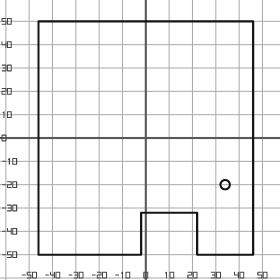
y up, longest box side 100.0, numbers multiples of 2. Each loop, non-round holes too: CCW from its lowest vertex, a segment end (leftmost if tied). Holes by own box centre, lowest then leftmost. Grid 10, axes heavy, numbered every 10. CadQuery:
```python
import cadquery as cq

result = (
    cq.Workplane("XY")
    .moveTo(-46.0, -50.0)
    .lineTo(-2.0, -50.0)
    .lineTo(-2.0, -32.0)
    .lineTo(22.0, -32.0)
    .lineTo(22.0, -50.0)
    .lineTo(46.0, -50.0)
    .lineTo(46.0, 50.0)
    .lineTo(-46.0, 50.0)
    .close()
    .moveTo(34.0, -20.0)
    .circle(2.0)
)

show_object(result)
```